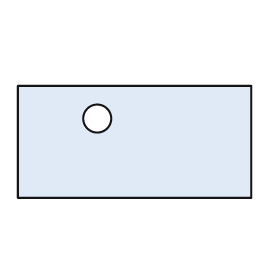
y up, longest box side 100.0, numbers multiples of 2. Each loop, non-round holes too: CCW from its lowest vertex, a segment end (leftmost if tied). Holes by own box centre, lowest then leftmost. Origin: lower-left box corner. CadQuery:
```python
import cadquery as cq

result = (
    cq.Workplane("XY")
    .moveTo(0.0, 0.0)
    .lineTo(100.0, 0.0)
    .lineTo(100.0, 48.0)
    .lineTo(0.0, 48.0)
    .close()
    .moveTo(34.0, 34.0)
    .circle(6.0)
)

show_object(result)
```